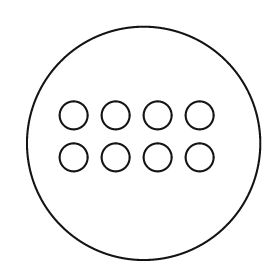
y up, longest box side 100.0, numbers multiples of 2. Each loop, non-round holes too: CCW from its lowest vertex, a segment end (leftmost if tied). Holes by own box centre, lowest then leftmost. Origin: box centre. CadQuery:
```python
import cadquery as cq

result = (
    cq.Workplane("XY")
    .moveTo(0.0, 0.0)
    .circle(50.0)
    .moveTo(-30.0, -6.0)
    .circle(6.0)
    .moveTo(-12.0, -6.0)
    .circle(6.0)
    .moveTo(6.0, -6.0)
    .circle(6.0)
    .moveTo(24.0, -6.0)
    .circle(6.0)
    .moveTo(-30.0, 12.0)
    .circle(6.0)
    .moveTo(-12.0, 12.0)
    .circle(6.0)
    .moveTo(6.0, 12.0)
    .circle(6.0)
    .moveTo(24.0, 12.0)
    .circle(6.0)
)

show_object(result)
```